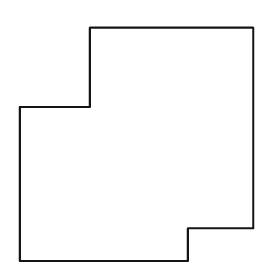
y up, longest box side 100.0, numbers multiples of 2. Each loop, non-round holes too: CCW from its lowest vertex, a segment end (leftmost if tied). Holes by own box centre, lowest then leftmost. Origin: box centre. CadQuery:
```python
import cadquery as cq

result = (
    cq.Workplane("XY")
    .moveTo(-50.0, -50.0)
    .lineTo(22.0, -50.0)
    .lineTo(22.0, -36.0)
    .lineTo(50.0, -36.0)
    .lineTo(50.0, 50.0)
    .lineTo(-20.0, 50.0)
    .lineTo(-20.0, 16.0)
    .lineTo(-50.0, 16.0)
    .close()
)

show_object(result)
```